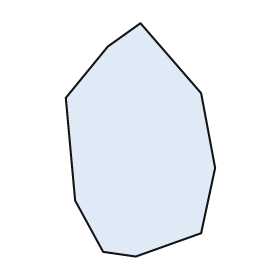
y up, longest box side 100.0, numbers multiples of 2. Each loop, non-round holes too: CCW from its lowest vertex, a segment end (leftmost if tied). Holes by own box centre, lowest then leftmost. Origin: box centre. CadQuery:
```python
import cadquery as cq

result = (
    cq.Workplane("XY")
    .moveTo(-2.0, -50.0)
    .lineTo(26.0, -40.0)
    .lineTo(32.0, -12.0)
    .lineTo(26.0, 20.0)
    .lineTo(0.0, 50.0)
    .lineTo(-14.0, 40.0)
    .lineTo(-32.0, 18.0)
    .lineTo(-28.0, -26.0)
    .lineTo(-16.0, -48.0)
    .close()
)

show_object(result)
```